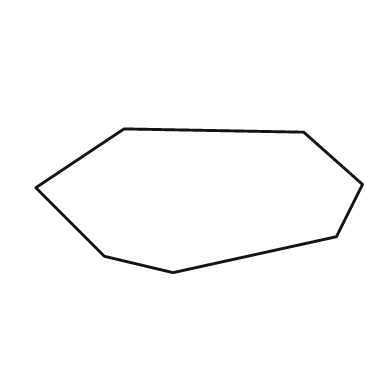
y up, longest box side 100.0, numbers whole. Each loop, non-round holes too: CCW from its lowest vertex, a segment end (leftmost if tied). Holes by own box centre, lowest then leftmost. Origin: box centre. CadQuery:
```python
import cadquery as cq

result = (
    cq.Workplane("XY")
    .moveTo(-8.0, -22.0)
    .lineTo(42.0, -11.0)
    .lineTo(50.0, 5.0)
    .lineTo(32.0, 21.0)
    .lineTo(-23.0, 22.0)
    .lineTo(-50.0, 4.0)
    .lineTo(-29.0, -17.0)
    .close()
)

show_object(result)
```